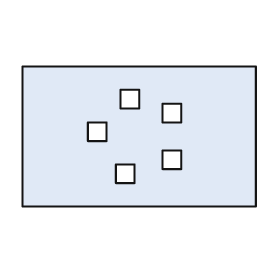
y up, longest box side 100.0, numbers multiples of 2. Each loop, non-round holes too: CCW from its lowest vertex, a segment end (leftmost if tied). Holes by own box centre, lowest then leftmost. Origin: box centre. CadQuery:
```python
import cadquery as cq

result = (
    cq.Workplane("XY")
    .moveTo(-50.0, -30.0)
    .lineTo(50.0, -30.0)
    .lineTo(50.0, 30.0)
    .lineTo(-50.0, 30.0)
    .close()
    .moveTo(-10.0, -20.0)
    .lineTo(-2.0, -20.0)
    .lineTo(-2.0, -12.0)
    .lineTo(-10.0, -12.0)
    .close()
    .moveTo(10.0, -14.0)
    .lineTo(18.0, -14.0)
    .lineTo(18.0, -6.0)
    .lineTo(10.0, -6.0)
    .close()
    .moveTo(-22.0, -2.0)
    .lineTo(-14.0, -2.0)
    .lineTo(-14.0, 6.0)
    .lineTo(-22.0, 6.0)
    .close()
    .moveTo(10.0, 6.0)
    .lineTo(18.0, 6.0)
    .lineTo(18.0, 14.0)
    .lineTo(10.0, 14.0)
    .close()
    .moveTo(-8.0, 12.0)
    .lineTo(0.0, 12.0)
    .lineTo(0.0, 20.0)
    .lineTo(-8.0, 20.0)
    .close()
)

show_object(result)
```